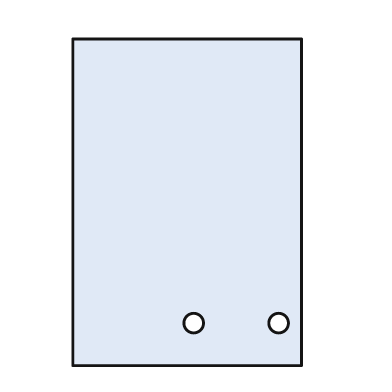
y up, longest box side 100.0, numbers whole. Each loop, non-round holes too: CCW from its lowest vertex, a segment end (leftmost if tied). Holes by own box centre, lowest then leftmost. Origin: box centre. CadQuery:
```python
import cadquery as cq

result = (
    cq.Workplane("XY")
    .moveTo(-35.0, -50.0)
    .lineTo(35.0, -50.0)
    .lineTo(35.0, 50.0)
    .lineTo(-35.0, 50.0)
    .close()
    .moveTo(2.0, -37.0)
    .circle(3.0)
    .moveTo(28.0, -37.0)
    .circle(3.0)
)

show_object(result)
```